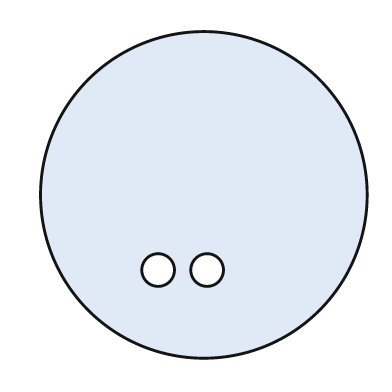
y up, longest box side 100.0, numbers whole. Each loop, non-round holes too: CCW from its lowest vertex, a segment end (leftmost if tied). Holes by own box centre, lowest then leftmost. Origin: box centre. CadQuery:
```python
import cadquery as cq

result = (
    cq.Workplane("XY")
    .moveTo(0.0, 0.0)
    .circle(50.0)
    .moveTo(-14.0, -23.0)
    .circle(5.0)
    .moveTo(1.0, -23.0)
    .circle(5.0)
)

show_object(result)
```